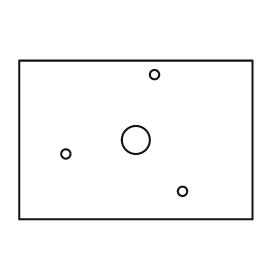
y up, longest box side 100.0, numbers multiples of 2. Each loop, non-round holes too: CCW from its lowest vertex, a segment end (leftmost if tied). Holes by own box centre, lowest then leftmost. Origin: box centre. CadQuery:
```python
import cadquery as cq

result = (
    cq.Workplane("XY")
    .moveTo(-50.0, -34.0)
    .lineTo(50.0, -34.0)
    .lineTo(50.0, 34.0)
    .lineTo(-50.0, 34.0)
    .close()
    .moveTo(20.0, -22.0)
    .circle(2.0)
    .moveTo(-30.0, -6.0)
    .circle(2.0)
    .moveTo(0.0, 0.0)
    .circle(6.0)
    .moveTo(8.0, 28.0)
    .circle(2.0)
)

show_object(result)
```